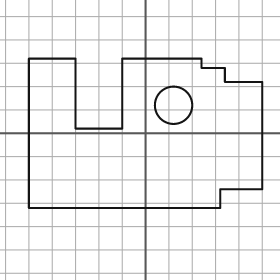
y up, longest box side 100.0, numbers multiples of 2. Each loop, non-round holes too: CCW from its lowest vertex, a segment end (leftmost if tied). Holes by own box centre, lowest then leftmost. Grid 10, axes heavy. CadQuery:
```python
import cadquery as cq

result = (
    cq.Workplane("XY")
    .moveTo(-50.0, -32.0)
    .lineTo(32.0, -32.0)
    .lineTo(32.0, -24.0)
    .lineTo(50.0, -24.0)
    .lineTo(50.0, 22.0)
    .lineTo(34.0, 22.0)
    .lineTo(34.0, 28.0)
    .lineTo(24.0, 28.0)
    .lineTo(24.0, 32.0)
    .lineTo(-10.0, 32.0)
    .lineTo(-10.0, 2.0)
    .lineTo(-30.0, 2.0)
    .lineTo(-30.0, 32.0)
    .lineTo(-50.0, 32.0)
    .close()
    .moveTo(12.0, 12.0)
    .circle(8.0)
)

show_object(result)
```